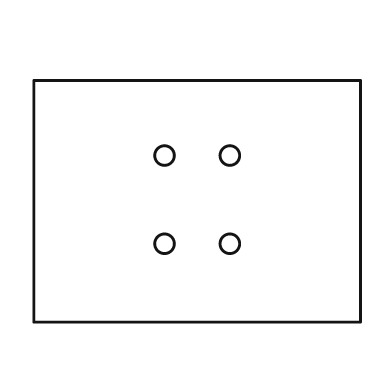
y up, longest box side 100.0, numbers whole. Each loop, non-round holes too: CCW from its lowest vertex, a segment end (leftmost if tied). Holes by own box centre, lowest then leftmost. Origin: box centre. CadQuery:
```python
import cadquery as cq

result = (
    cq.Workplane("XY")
    .moveTo(-50.0, -37.0)
    .lineTo(50.0, -37.0)
    .lineTo(50.0, 37.0)
    .lineTo(-50.0, 37.0)
    .close()
    .moveTo(-10.0, -13.0)
    .circle(3.0)
    .moveTo(10.0, -13.0)
    .circle(3.0)
    .moveTo(-10.0, 14.0)
    .circle(3.0)
    .moveTo(10.0, 14.0)
    .circle(3.0)
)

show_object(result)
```